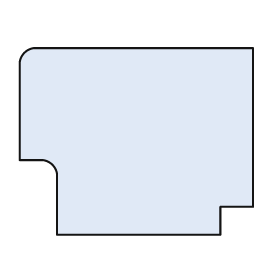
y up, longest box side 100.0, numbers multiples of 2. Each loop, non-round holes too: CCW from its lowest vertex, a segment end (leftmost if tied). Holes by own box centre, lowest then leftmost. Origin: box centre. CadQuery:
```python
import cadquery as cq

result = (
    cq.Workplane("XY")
    .moveTo(-34.0, -40.0)
    .lineTo(36.0, -40.0)
    .lineTo(36.0, -28.0)
    .lineTo(50.0, -28.0)
    .lineTo(50.0, 40.0)
    .lineTo(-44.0, 40.0)
    .threePointArc((-48.0, 38.0), (-50.0, 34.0))
    .lineTo(-50.0, -8.0)
    .lineTo(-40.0, -8.0)
    .threePointArc((-36.0, -10.0), (-34.0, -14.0))
    .close()
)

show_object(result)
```